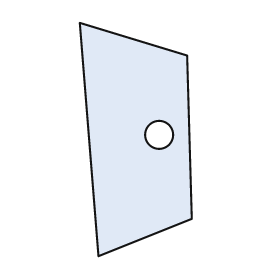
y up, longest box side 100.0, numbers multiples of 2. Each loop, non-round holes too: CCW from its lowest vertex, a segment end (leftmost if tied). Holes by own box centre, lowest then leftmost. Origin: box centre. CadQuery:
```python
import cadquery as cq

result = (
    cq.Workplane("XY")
    .moveTo(-16.0, -50.0)
    .lineTo(24.0, -34.0)
    .lineTo(22.0, 36.0)
    .lineTo(-24.0, 50.0)
    .close()
    .moveTo(10.0, 2.0)
    .circle(6.0)
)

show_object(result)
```